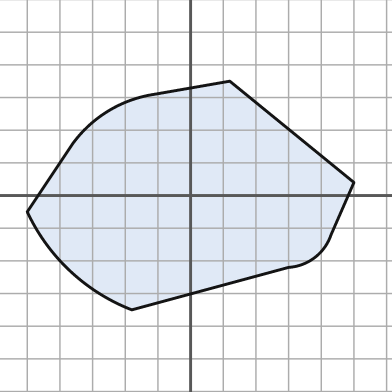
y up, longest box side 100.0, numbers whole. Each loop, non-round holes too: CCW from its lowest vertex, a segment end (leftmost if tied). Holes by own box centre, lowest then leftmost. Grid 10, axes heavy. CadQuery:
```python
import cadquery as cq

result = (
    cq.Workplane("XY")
    .moveTo(-18.0, -35.0)
    .lineTo(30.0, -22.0)
    .threePointArc((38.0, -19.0), (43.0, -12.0))
    .lineTo(50.0, 4.0)
    .lineTo(12.0, 35.0)
    .lineTo(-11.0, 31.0)
    .threePointArc((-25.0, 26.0), (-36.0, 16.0))
    .lineTo(-50.0, -5.0)
    .threePointArc((-37.0, -23.0), (-18.0, -35.0))
    .close()
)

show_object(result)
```